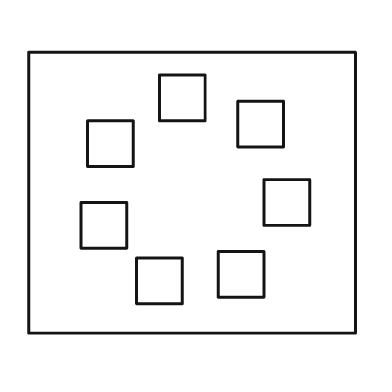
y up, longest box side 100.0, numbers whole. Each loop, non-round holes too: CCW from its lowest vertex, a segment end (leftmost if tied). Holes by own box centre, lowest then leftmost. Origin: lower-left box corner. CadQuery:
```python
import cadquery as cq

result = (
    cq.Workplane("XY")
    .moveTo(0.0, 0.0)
    .lineTo(100.0, 0.0)
    .lineTo(100.0, 86.0)
    .lineTo(0.0, 86.0)
    .close()
    .moveTo(33.0, 9.0)
    .lineTo(47.0, 9.0)
    .lineTo(47.0, 23.0)
    .lineTo(33.0, 23.0)
    .close()
    .moveTo(58.0, 11.0)
    .lineTo(72.0, 11.0)
    .lineTo(72.0, 25.0)
    .lineTo(58.0, 25.0)
    .close()
    .moveTo(16.0, 26.0)
    .lineTo(30.0, 26.0)
    .lineTo(30.0, 40.0)
    .lineTo(16.0, 40.0)
    .close()
    .moveTo(72.0, 33.0)
    .lineTo(86.0, 33.0)
    .lineTo(86.0, 47.0)
    .lineTo(72.0, 47.0)
    .close()
    .moveTo(18.0, 51.0)
    .lineTo(32.0, 51.0)
    .lineTo(32.0, 65.0)
    .lineTo(18.0, 65.0)
    .close()
    .moveTo(64.0, 57.0)
    .lineTo(78.0, 57.0)
    .lineTo(78.0, 71.0)
    .lineTo(64.0, 71.0)
    .close()
    .moveTo(40.0, 65.0)
    .lineTo(54.0, 65.0)
    .lineTo(54.0, 79.0)
    .lineTo(40.0, 79.0)
    .close()
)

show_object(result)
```